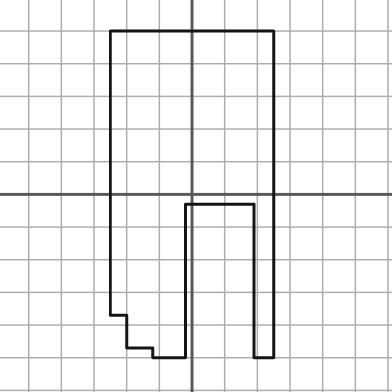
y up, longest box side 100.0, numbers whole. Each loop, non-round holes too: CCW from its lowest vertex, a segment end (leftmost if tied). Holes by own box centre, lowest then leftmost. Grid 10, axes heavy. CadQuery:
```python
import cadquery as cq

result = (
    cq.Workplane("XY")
    .moveTo(-12.0, -50.0)
    .lineTo(-2.0, -50.0)
    .lineTo(-2.0, -3.0)
    .lineTo(19.0, -3.0)
    .lineTo(19.0, -50.0)
    .lineTo(25.0, -50.0)
    .lineTo(25.0, 50.0)
    .lineTo(-25.0, 50.0)
    .lineTo(-25.0, -37.0)
    .lineTo(-20.0, -37.0)
    .lineTo(-20.0, -47.0)
    .lineTo(-12.0, -47.0)
    .close()
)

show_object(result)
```